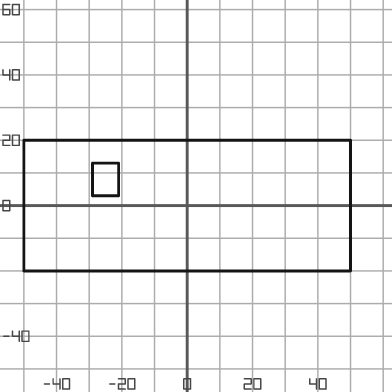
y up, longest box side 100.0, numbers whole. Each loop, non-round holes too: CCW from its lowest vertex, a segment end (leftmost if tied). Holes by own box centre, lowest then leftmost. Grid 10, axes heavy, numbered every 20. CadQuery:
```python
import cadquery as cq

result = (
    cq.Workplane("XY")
    .moveTo(-50.0, -20.0)
    .lineTo(50.0, -20.0)
    .lineTo(50.0, 20.0)
    .lineTo(-50.0, 20.0)
    .close()
    .moveTo(-29.0, 3.0)
    .lineTo(-21.0, 3.0)
    .lineTo(-21.0, 13.0)
    .lineTo(-29.0, 13.0)
    .close()
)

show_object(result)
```